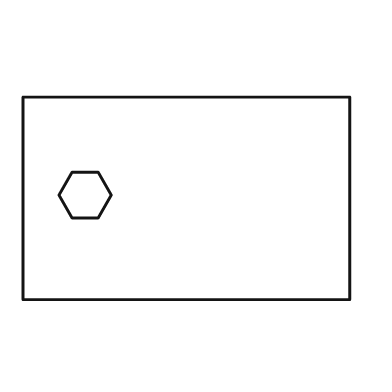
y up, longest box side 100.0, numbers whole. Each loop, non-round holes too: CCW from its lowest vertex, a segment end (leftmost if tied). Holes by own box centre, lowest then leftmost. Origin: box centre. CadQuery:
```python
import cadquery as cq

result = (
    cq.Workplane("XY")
    .moveTo(-50.0, -31.0)
    .lineTo(50.0, -31.0)
    .lineTo(50.0, 31.0)
    .lineTo(-50.0, 31.0)
    .close()
    .moveTo(-35.0, -6.0)
    .lineTo(-27.0, -6.0)
    .lineTo(-23.0, 1.0)
    .lineTo(-27.0, 8.0)
    .lineTo(-35.0, 8.0)
    .lineTo(-39.0, 1.0)
    .close()
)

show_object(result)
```